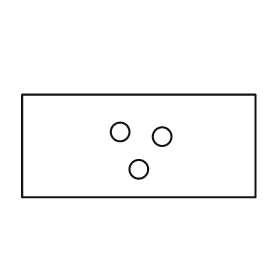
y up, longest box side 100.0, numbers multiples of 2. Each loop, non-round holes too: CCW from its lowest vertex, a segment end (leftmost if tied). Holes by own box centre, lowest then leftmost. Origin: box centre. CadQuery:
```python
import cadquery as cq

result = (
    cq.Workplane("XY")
    .moveTo(-50.0, -22.0)
    .lineTo(50.0, -22.0)
    .lineTo(50.0, 22.0)
    .lineTo(-50.0, 22.0)
    .close()
    .moveTo(0.0, -10.0)
    .circle(4.0)
    .moveTo(10.0, 4.0)
    .circle(4.0)
    .moveTo(-8.0, 6.0)
    .circle(4.0)
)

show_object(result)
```